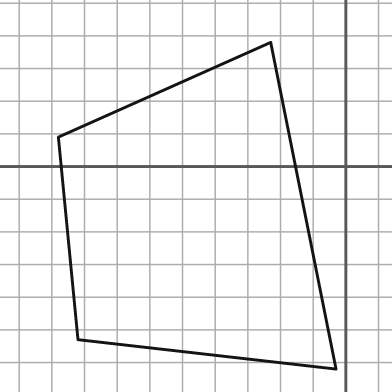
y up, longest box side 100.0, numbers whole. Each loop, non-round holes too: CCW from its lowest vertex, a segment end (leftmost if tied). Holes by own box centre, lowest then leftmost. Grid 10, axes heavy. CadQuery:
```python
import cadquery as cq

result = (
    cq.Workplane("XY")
    .moveTo(-3.0, -62.0)
    .lineTo(-23.0, 38.0)
    .lineTo(-88.0, 9.0)
    .lineTo(-82.0, -53.0)
    .close()
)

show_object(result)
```